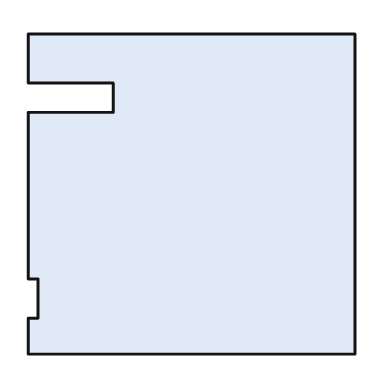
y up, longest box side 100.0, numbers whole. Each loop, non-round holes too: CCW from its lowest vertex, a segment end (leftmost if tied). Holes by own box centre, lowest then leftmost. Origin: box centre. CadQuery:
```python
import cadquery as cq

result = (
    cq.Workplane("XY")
    .moveTo(-50.0, -49.0)
    .lineTo(50.0, -49.0)
    .lineTo(50.0, 49.0)
    .lineTo(-50.0, 49.0)
    .lineTo(-50.0, 34.0)
    .lineTo(-24.0, 34.0)
    .lineTo(-24.0, 25.0)
    .lineTo(-50.0, 25.0)
    .lineTo(-50.0, -26.0)
    .lineTo(-47.0, -26.0)
    .lineTo(-47.0, -38.0)
    .lineTo(-50.0, -38.0)
    .close()
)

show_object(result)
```